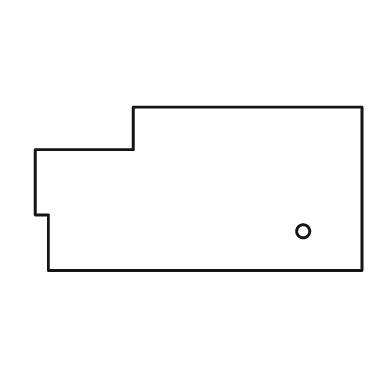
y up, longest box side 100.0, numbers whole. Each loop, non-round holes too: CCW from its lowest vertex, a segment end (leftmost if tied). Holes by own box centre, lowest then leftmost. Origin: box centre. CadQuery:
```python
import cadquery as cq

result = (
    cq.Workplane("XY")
    .moveTo(-46.0, -25.0)
    .lineTo(50.0, -25.0)
    .lineTo(50.0, 25.0)
    .lineTo(-20.0, 25.0)
    .lineTo(-20.0, 12.0)
    .lineTo(-50.0, 12.0)
    .lineTo(-50.0, -8.0)
    .lineTo(-46.0, -8.0)
    .close()
    .moveTo(32.0, -13.0)
    .circle(2.0)
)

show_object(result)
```